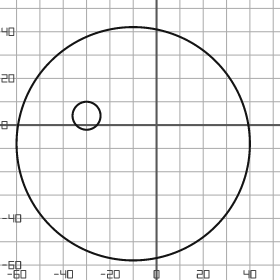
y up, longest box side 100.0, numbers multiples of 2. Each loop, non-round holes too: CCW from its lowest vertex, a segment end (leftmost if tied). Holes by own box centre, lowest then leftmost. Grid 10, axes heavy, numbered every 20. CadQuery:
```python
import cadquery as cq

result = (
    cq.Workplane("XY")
    .moveTo(-10.0, -8.0)
    .circle(50.0)
    .moveTo(-30.0, 4.0)
    .circle(6.0)
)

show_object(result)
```